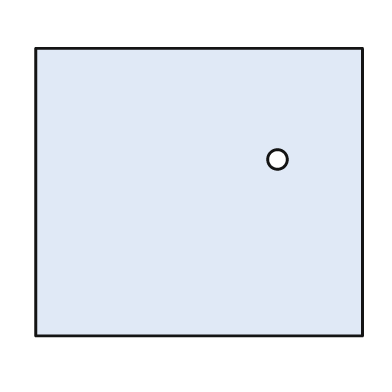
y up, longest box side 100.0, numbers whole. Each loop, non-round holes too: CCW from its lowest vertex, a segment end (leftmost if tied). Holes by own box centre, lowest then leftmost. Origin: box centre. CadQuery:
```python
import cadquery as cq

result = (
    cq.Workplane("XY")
    .moveTo(-50.0, -44.0)
    .lineTo(50.0, -44.0)
    .lineTo(50.0, 44.0)
    .lineTo(-50.0, 44.0)
    .close()
    .moveTo(24.0, 10.0)
    .circle(3.0)
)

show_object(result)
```